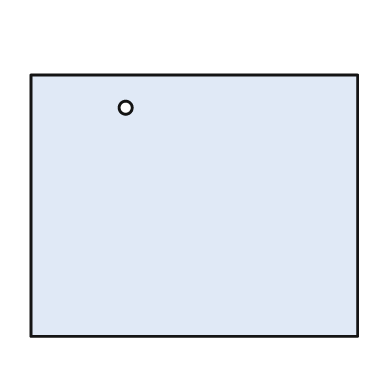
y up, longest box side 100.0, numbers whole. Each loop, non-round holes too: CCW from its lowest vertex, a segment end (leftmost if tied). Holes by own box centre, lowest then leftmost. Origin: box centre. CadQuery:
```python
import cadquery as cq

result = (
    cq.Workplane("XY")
    .moveTo(-50.0, -40.0)
    .lineTo(50.0, -40.0)
    .lineTo(50.0, 40.0)
    .lineTo(-50.0, 40.0)
    .close()
    .moveTo(-21.0, 30.0)
    .circle(2.0)
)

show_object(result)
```